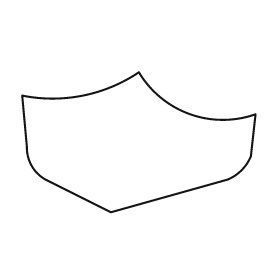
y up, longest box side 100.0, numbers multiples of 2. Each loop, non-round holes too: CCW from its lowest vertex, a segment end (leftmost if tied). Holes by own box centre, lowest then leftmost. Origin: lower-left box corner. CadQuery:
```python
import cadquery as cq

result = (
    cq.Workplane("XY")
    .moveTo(38.0, 0.0)
    .lineTo(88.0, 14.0)
    .threePointArc((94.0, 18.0), (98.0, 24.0))
    .lineTo(100.0, 42.0)
    .threePointArc((72.0, 42.0), (50.0, 60.0))
    .threePointArc((26.0, 50.0), (0.0, 50.0))
    .lineTo(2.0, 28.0)
    .threePointArc((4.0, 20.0), (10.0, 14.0))
    .close()
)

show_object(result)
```